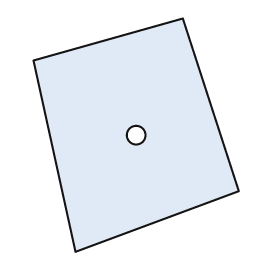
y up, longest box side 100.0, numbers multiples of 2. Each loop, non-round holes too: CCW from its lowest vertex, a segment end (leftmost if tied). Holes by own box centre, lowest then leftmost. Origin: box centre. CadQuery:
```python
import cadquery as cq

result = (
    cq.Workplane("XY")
    .moveTo(-26.0, -50.0)
    .lineTo(44.0, -24.0)
    .lineTo(20.0, 50.0)
    .lineTo(-44.0, 32.0)
    .close()
    .moveTo(0.0, 0.0)
    .circle(4.0)
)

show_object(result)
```